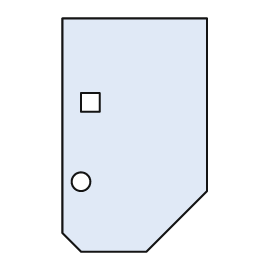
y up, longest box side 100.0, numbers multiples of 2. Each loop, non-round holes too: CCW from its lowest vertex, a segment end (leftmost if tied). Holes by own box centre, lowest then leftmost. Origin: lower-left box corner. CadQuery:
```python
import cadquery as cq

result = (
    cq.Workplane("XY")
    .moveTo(8.0, 0.0)
    .lineTo(36.0, 0.0)
    .lineTo(62.0, 26.0)
    .lineTo(62.0, 100.0)
    .lineTo(0.0, 100.0)
    .lineTo(0.0, 8.0)
    .close()
    .moveTo(8.0, 30.0)
    .circle(4.0)
    .moveTo(8.0, 60.0)
    .lineTo(16.0, 60.0)
    .lineTo(16.0, 68.0)
    .lineTo(8.0, 68.0)
    .close()
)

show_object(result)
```